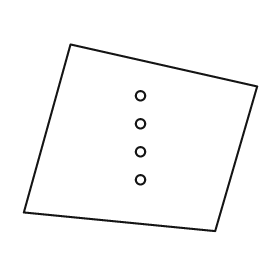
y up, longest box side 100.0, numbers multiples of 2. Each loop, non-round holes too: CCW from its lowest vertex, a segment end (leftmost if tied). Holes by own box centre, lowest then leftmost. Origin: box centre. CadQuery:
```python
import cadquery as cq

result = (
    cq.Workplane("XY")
    .moveTo(32.0, -40.0)
    .lineTo(50.0, 22.0)
    .lineTo(-30.0, 40.0)
    .lineTo(-50.0, -32.0)
    .close()
    .moveTo(0.0, -18.0)
    .circle(2.0)
    .moveTo(0.0, -6.0)
    .circle(2.0)
    .moveTo(0.0, 6.0)
    .circle(2.0)
    .moveTo(0.0, 18.0)
    .circle(2.0)
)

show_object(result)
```